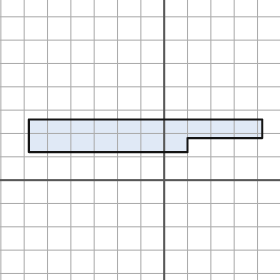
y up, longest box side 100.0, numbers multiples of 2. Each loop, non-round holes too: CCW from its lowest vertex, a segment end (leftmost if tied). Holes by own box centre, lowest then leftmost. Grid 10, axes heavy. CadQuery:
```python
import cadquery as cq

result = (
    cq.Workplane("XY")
    .moveTo(-58.0, 12.0)
    .lineTo(10.0, 12.0)
    .lineTo(10.0, 18.0)
    .lineTo(42.0, 18.0)
    .lineTo(42.0, 26.0)
    .lineTo(-58.0, 26.0)
    .close()
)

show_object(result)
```